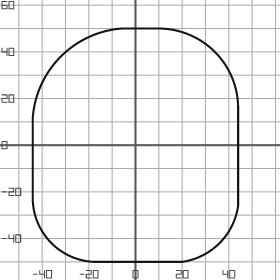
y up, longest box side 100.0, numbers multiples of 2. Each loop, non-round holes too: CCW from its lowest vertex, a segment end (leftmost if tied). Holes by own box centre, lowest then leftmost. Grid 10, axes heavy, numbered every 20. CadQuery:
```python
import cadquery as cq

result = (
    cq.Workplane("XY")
    .moveTo(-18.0, -50.0)
    .lineTo(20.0, -50.0)
    .threePointArc((36.0, -42.0), (44.0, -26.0))
    .lineTo(44.0, 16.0)
    .threePointArc((34.0, 40.0), (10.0, 50.0))
    .lineTo(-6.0, 50.0)
    .threePointArc((-32.0, 38.0), (-44.0, 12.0))
    .lineTo(-44.0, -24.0)
    .threePointArc((-36.0, -42.0), (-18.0, -50.0))
    .close()
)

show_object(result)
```